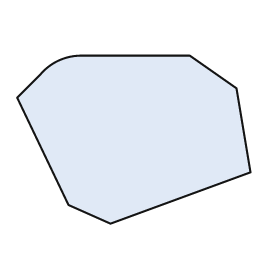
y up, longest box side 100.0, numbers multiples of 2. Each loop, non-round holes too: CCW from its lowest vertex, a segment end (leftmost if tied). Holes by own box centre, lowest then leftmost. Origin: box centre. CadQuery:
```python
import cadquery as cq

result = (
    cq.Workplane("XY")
    .moveTo(-10.0, -36.0)
    .lineTo(50.0, -14.0)
    .lineTo(44.0, 22.0)
    .lineTo(24.0, 36.0)
    .lineTo(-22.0, 36.0)
    .threePointArc((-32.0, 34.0), (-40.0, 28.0))
    .lineTo(-50.0, 18.0)
    .lineTo(-28.0, -28.0)
    .close()
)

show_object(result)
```